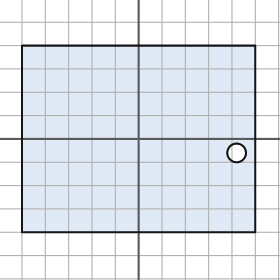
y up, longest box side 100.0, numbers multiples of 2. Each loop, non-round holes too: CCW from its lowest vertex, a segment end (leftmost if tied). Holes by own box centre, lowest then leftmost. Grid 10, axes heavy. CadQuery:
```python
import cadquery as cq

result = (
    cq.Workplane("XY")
    .moveTo(-50.0, -40.0)
    .lineTo(50.0, -40.0)
    .lineTo(50.0, 40.0)
    .lineTo(-50.0, 40.0)
    .close()
    .moveTo(42.0, -6.0)
    .circle(4.0)
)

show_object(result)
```